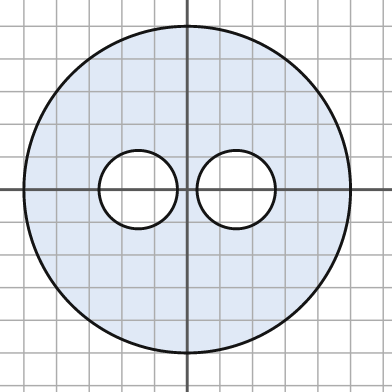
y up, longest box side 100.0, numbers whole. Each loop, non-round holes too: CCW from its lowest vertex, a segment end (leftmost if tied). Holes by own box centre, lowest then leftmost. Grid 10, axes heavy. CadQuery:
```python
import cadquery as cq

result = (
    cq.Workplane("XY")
    .moveTo(0.0, 0.0)
    .circle(50.0)
    .moveTo(-15.0, 0.0)
    .circle(12.0)
    .moveTo(15.0, 0.0)
    .circle(12.0)
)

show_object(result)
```